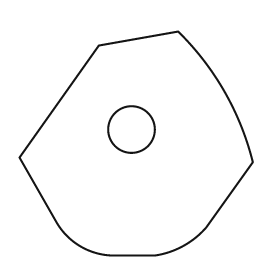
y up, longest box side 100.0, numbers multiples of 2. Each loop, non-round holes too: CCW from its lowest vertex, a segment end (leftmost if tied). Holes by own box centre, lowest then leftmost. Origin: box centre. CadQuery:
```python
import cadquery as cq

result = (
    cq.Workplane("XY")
    .moveTo(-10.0, -48.0)
    .lineTo(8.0, -48.0)
    .threePointArc((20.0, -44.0), (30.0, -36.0))
    .lineTo(50.0, -8.0)
    .threePointArc((38.0, 22.0), (18.0, 48.0))
    .lineTo(-16.0, 42.0)
    .lineTo(-50.0, -6.0)
    .lineTo(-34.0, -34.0)
    .threePointArc((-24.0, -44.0), (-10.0, -48.0))
    .close()
    .moveTo(-2.0, 6.0)
    .circle(10.0)
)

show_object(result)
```